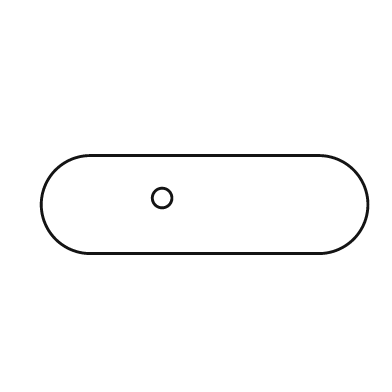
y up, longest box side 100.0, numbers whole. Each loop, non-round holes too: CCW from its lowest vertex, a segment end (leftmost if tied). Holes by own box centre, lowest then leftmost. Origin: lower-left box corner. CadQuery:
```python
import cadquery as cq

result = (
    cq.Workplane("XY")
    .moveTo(15.0, 0.0)
    .lineTo(85.0, 0.0)
    .threePointArc((100.0, 15.0), (85.0, 30.0))
    .lineTo(15.0, 30.0)
    .threePointArc((0.0, 15.0), (15.0, 0.0))
    .close()
    .moveTo(37.0, 17.0)
    .circle(3.0)
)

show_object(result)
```